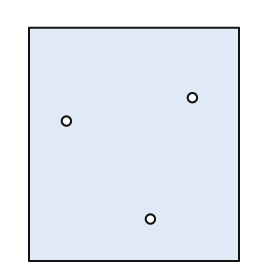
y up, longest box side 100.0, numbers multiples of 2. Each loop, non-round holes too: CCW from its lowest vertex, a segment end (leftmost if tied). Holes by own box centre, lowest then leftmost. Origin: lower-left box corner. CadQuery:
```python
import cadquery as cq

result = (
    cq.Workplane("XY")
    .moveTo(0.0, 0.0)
    .lineTo(90.0, 0.0)
    .lineTo(90.0, 100.0)
    .lineTo(0.0, 100.0)
    .close()
    .moveTo(52.0, 18.0)
    .circle(2.0)
    .moveTo(16.0, 60.0)
    .circle(2.0)
    .moveTo(70.0, 70.0)
    .circle(2.0)
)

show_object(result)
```